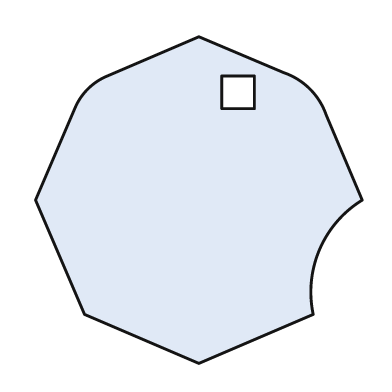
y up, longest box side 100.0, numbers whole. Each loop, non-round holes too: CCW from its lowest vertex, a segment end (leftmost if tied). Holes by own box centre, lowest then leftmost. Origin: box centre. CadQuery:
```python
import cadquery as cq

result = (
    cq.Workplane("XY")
    .moveTo(0.0, -50.0)
    .lineTo(35.0, -35.0)
    .threePointArc((37.0, -15.0), (50.0, 0.0))
    .lineTo(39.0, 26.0)
    .threePointArc((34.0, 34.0), (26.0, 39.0))
    .lineTo(0.0, 50.0)
    .lineTo(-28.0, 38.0)
    .threePointArc((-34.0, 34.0), (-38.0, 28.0))
    .lineTo(-50.0, 0.0)
    .lineTo(-35.0, -35.0)
    .close()
    .moveTo(7.0, 28.0)
    .lineTo(17.0, 28.0)
    .lineTo(17.0, 38.0)
    .lineTo(7.0, 38.0)
    .close()
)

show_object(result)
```